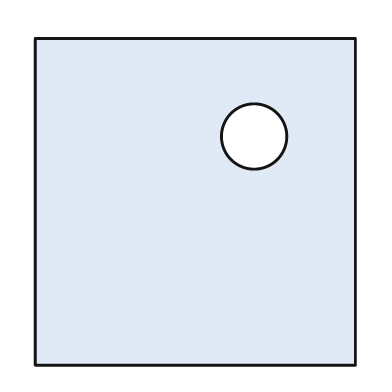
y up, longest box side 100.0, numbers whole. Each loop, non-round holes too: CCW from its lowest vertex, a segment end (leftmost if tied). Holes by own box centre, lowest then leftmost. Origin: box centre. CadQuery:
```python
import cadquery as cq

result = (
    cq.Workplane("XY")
    .moveTo(-49.0, -50.0)
    .lineTo(49.0, -50.0)
    .lineTo(49.0, 50.0)
    .lineTo(-49.0, 50.0)
    .close()
    .moveTo(18.0, 20.0)
    .circle(10.0)
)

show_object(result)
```